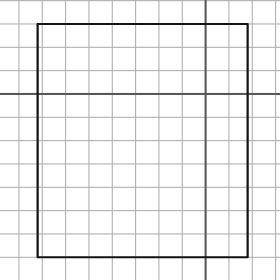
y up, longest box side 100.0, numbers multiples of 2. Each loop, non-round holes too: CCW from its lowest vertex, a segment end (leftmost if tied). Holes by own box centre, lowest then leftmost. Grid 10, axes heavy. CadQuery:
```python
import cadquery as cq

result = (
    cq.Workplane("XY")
    .moveTo(-72.0, -70.0)
    .lineTo(18.0, -70.0)
    .lineTo(18.0, 30.0)
    .lineTo(-72.0, 30.0)
    .close()
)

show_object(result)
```